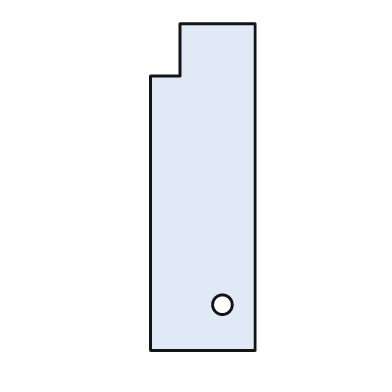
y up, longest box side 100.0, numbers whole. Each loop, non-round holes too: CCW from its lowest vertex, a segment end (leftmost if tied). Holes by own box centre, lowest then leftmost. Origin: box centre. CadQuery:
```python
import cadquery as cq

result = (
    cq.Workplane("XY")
    .moveTo(-16.0, -50.0)
    .lineTo(16.0, -50.0)
    .lineTo(16.0, 50.0)
    .lineTo(-7.0, 50.0)
    .lineTo(-7.0, 34.0)
    .lineTo(-16.0, 34.0)
    .close()
    .moveTo(6.0, -36.0)
    .circle(3.0)
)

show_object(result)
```